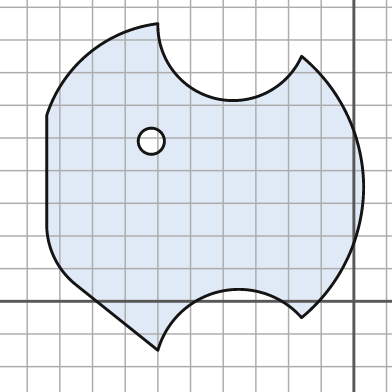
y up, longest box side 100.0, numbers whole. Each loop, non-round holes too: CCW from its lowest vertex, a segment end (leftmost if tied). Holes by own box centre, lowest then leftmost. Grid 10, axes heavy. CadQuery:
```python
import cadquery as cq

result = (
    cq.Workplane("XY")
    .moveTo(-60.0, -15.0)
    .threePointArc((-41.0, 3.0), (-16.0, -5.0))
    .threePointArc((-2.0, 13.0), (3.0, 35.0))
    .threePointArc((-2.0, 57.0), (-16.0, 75.0))
    .threePointArc((-42.0, 62.0), (-60.0, 85.0))
    .threePointArc((-81.0, 76.0), (-94.0, 57.0))
    .lineTo(-94.0, 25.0)
    .threePointArc((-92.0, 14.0), (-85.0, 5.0))
    .close()
    .moveTo(-62.0, 49.0)
    .circle(4.0)
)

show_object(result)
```